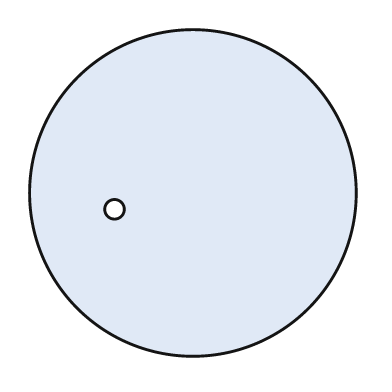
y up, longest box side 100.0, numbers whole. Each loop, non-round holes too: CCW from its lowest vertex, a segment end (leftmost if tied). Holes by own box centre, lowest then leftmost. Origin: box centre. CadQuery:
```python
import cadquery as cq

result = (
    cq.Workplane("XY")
    .moveTo(0.0, 0.0)
    .circle(50.0)
    .moveTo(-24.0, -5.0)
    .circle(3.0)
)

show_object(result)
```